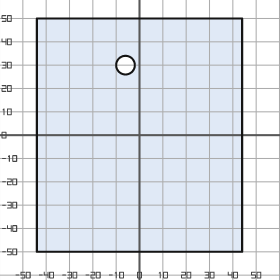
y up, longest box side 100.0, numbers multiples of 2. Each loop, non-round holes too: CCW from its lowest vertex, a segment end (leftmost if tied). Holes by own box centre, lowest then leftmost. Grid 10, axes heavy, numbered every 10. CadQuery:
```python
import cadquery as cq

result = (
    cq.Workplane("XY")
    .moveTo(-44.0, -50.0)
    .lineTo(44.0, -50.0)
    .lineTo(44.0, 50.0)
    .lineTo(-44.0, 50.0)
    .close()
    .moveTo(-6.0, 30.0)
    .circle(4.0)
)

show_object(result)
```